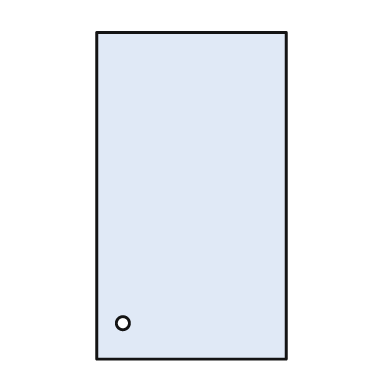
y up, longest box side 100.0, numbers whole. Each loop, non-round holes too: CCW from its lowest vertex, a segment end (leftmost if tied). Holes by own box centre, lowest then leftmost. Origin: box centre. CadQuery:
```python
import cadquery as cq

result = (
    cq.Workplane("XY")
    .moveTo(-29.0, -50.0)
    .lineTo(29.0, -50.0)
    .lineTo(29.0, 50.0)
    .lineTo(-29.0, 50.0)
    .close()
    .moveTo(-21.0, -39.0)
    .circle(2.0)
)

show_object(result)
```